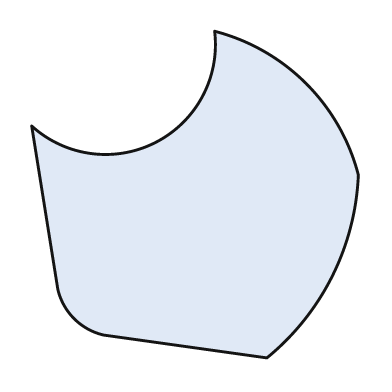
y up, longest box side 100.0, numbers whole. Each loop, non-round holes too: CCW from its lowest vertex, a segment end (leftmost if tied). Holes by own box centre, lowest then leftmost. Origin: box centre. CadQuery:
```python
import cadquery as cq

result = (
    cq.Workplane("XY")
    .moveTo(22.0, -50.0)
    .threePointArc((42.0, -25.0), (50.0, 6.0))
    .threePointArc((34.0, 34.0), (6.0, 50.0))
    .threePointArc((-12.0, 16.0), (-50.0, 21.0))
    .lineTo(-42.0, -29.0)
    .threePointArc((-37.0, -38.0), (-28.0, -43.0))
    .close()
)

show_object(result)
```